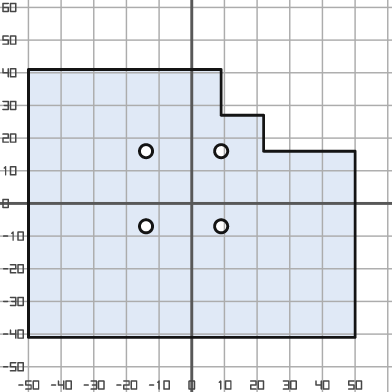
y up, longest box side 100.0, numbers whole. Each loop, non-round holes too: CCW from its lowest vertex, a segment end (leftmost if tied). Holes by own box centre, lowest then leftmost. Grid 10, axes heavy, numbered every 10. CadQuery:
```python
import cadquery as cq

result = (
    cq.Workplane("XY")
    .moveTo(-50.0, -41.0)
    .lineTo(50.0, -41.0)
    .lineTo(50.0, 16.0)
    .lineTo(22.0, 16.0)
    .lineTo(22.0, 27.0)
    .lineTo(9.0, 27.0)
    .lineTo(9.0, 41.0)
    .lineTo(-50.0, 41.0)
    .close()
    .moveTo(-14.0, -7.0)
    .circle(2.0)
    .moveTo(9.0, -7.0)
    .circle(2.0)
    .moveTo(-14.0, 16.0)
    .circle(2.0)
    .moveTo(9.0, 16.0)
    .circle(2.0)
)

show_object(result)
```